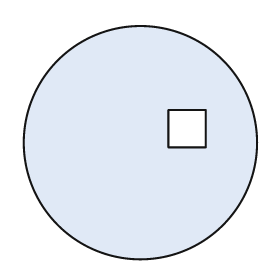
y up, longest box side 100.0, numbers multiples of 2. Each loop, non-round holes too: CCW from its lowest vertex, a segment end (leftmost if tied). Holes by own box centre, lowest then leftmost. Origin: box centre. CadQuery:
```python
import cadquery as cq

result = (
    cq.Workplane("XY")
    .moveTo(0.0, 0.0)
    .circle(50.0)
    .moveTo(12.0, -2.0)
    .lineTo(28.0, -2.0)
    .lineTo(28.0, 14.0)
    .lineTo(12.0, 14.0)
    .close()
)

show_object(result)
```